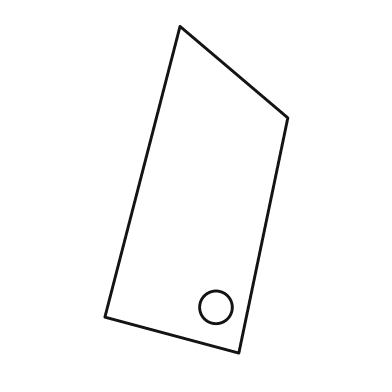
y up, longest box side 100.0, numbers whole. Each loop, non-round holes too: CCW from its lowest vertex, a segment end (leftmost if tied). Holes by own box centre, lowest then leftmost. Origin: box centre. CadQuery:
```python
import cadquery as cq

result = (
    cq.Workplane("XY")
    .moveTo(13.0, -50.0)
    .lineTo(28.0, 22.0)
    .lineTo(-5.0, 50.0)
    .lineTo(-28.0, -39.0)
    .close()
    .moveTo(6.0, -36.0)
    .circle(5.0)
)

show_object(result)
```